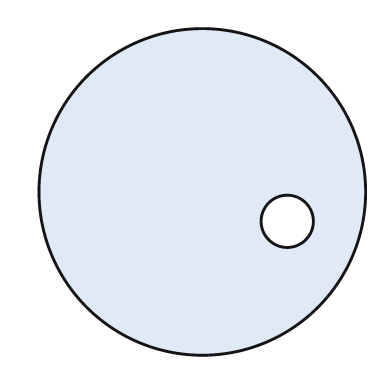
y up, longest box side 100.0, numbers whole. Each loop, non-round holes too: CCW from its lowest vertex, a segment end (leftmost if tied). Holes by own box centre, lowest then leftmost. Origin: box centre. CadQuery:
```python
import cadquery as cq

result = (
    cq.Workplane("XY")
    .moveTo(0.0, 0.0)
    .circle(50.0)
    .moveTo(26.0, -9.0)
    .circle(8.0)
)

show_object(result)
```